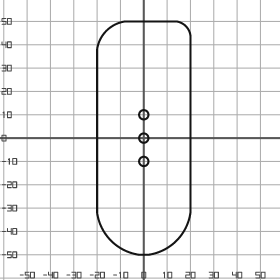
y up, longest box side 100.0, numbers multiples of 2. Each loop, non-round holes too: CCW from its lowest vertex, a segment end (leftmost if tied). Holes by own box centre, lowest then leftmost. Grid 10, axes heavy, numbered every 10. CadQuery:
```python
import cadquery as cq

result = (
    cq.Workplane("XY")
    .moveTo(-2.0, -50.0)
    .lineTo(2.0, -50.0)
    .threePointArc((14.0, -44.0), (20.0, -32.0))
    .lineTo(20.0, 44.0)
    .threePointArc((18.0, 48.0), (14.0, 50.0))
    .lineTo(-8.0, 50.0)
    .threePointArc((-16.0, 46.0), (-20.0, 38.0))
    .lineTo(-20.0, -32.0)
    .threePointArc((-14.0, -44.0), (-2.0, -50.0))
    .close()
    .moveTo(0.0, -10.0)
    .circle(2.0)
    .moveTo(0.0, 0.0)
    .circle(2.0)
    .moveTo(0.0, 10.0)
    .circle(2.0)
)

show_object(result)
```